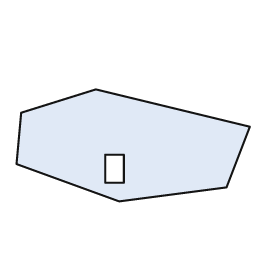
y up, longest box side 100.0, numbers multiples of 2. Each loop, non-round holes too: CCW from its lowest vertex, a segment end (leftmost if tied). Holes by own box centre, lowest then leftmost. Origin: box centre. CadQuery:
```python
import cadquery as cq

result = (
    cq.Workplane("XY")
    .moveTo(-6.0, -24.0)
    .lineTo(40.0, -18.0)
    .lineTo(50.0, 8.0)
    .lineTo(-16.0, 24.0)
    .lineTo(-48.0, 14.0)
    .lineTo(-50.0, -8.0)
    .close()
    .moveTo(-12.0, -16.0)
    .lineTo(-4.0, -16.0)
    .lineTo(-4.0, -4.0)
    .lineTo(-12.0, -4.0)
    .close()
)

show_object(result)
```